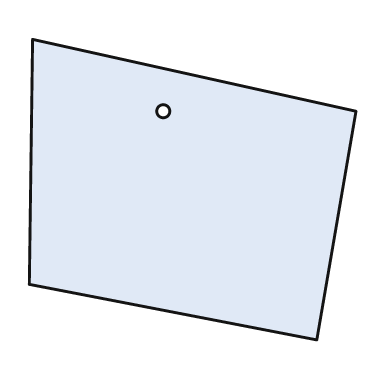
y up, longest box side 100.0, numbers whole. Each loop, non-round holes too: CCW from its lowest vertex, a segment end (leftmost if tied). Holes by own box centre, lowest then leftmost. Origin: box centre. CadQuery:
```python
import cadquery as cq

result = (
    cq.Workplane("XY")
    .moveTo(38.0, -46.0)
    .lineTo(50.0, 24.0)
    .lineTo(-49.0, 46.0)
    .lineTo(-50.0, -29.0)
    .close()
    .moveTo(-9.0, 24.0)
    .circle(2.0)
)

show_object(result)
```